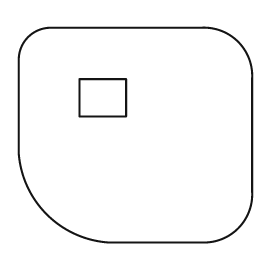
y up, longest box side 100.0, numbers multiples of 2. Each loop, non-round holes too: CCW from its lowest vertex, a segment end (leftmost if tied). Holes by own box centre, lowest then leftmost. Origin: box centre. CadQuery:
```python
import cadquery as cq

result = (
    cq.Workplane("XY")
    .moveTo(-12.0, -46.0)
    .lineTo(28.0, -46.0)
    .threePointArc((44.0, -40.0), (50.0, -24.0))
    .lineTo(50.0, 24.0)
    .threePointArc((44.0, 40.0), (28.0, 46.0))
    .lineTo(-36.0, 46.0)
    .threePointArc((-46.0, 42.0), (-50.0, 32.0))
    .lineTo(-50.0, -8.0)
    .threePointArc((-38.0, -34.0), (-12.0, -46.0))
    .close()
    .moveTo(-24.0, 8.0)
    .lineTo(-4.0, 8.0)
    .lineTo(-4.0, 24.0)
    .lineTo(-24.0, 24.0)
    .close()
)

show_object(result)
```